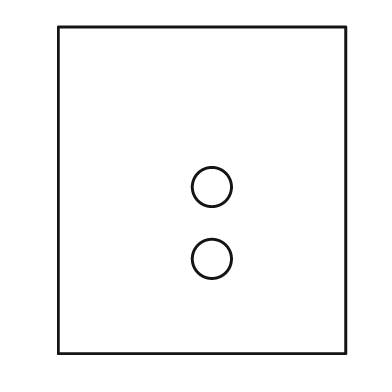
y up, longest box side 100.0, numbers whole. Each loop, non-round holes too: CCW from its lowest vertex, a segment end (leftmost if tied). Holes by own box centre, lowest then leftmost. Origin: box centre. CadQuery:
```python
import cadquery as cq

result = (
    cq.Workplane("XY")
    .moveTo(-44.0, -50.0)
    .lineTo(44.0, -50.0)
    .lineTo(44.0, 50.0)
    .lineTo(-44.0, 50.0)
    .close()
    .moveTo(3.0, -21.0)
    .circle(6.0)
    .moveTo(3.0, 1.0)
    .circle(6.0)
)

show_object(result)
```